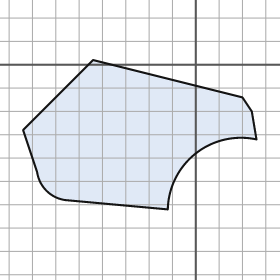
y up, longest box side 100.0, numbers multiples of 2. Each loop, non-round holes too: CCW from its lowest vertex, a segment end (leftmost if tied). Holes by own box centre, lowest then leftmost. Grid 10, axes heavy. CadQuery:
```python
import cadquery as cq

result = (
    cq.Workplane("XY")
    .moveTo(-12.0, -62.0)
    .threePointArc((0.0, -38.0), (26.0, -32.0))
    .lineTo(24.0, -20.0)
    .lineTo(20.0, -14.0)
    .lineTo(-44.0, 2.0)
    .lineTo(-74.0, -28.0)
    .lineTo(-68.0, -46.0)
    .threePointArc((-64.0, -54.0), (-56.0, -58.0))
    .close()
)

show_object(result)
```